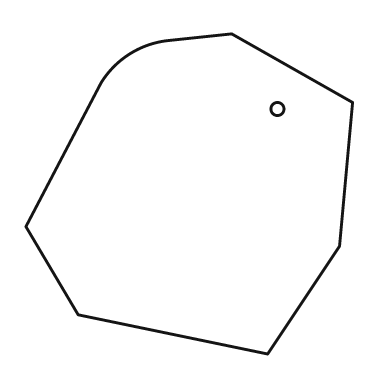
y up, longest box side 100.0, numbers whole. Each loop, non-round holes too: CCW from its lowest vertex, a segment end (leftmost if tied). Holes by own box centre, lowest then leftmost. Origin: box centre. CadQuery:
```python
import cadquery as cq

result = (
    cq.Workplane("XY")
    .moveTo(24.0, -49.0)
    .lineTo(46.0, -16.0)
    .lineTo(50.0, 28.0)
    .lineTo(13.0, 49.0)
    .lineTo(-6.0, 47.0)
    .threePointArc((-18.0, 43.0), (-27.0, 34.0))
    .lineTo(-50.0, -10.0)
    .lineTo(-34.0, -37.0)
    .close()
    .moveTo(27.0, 26.0)
    .circle(2.0)
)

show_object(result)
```